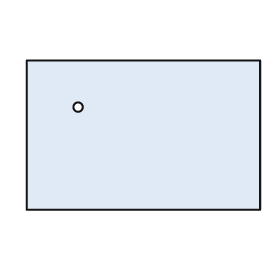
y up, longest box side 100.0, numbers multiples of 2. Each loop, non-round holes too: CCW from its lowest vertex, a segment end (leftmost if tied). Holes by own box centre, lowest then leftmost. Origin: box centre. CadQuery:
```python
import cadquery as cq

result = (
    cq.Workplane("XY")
    .moveTo(-50.0, -32.0)
    .lineTo(50.0, -32.0)
    .lineTo(50.0, 32.0)
    .lineTo(-50.0, 32.0)
    .close()
    .moveTo(-28.0, 12.0)
    .circle(2.0)
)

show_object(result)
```